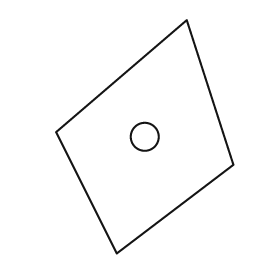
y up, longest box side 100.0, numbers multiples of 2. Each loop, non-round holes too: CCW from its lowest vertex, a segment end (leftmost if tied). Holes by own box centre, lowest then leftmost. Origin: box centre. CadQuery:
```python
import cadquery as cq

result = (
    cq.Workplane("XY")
    .moveTo(-12.0, -50.0)
    .lineTo(38.0, -12.0)
    .lineTo(18.0, 50.0)
    .lineTo(-38.0, 2.0)
    .close()
    .moveTo(0.0, 0.0)
    .circle(6.0)
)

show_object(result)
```